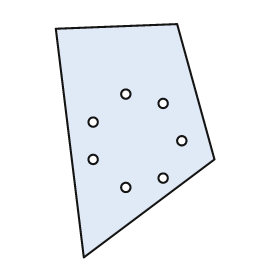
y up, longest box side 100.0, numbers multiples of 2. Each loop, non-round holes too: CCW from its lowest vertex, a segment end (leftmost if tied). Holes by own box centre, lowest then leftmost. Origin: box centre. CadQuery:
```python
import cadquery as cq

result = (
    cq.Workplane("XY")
    .moveTo(-22.0, -50.0)
    .lineTo(34.0, -8.0)
    .lineTo(18.0, 50.0)
    .lineTo(-34.0, 48.0)
    .close()
    .moveTo(-4.0, -20.0)
    .circle(2.0)
    .moveTo(12.0, -16.0)
    .circle(2.0)
    .moveTo(-18.0, -8.0)
    .circle(2.0)
    .moveTo(20.0, 0.0)
    .circle(2.0)
    .moveTo(-18.0, 8.0)
    .circle(2.0)
    .moveTo(12.0, 16.0)
    .circle(2.0)
    .moveTo(-4.0, 20.0)
    .circle(2.0)
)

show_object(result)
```